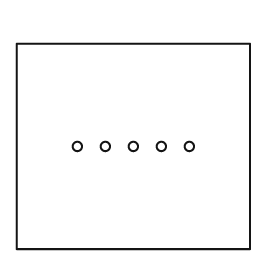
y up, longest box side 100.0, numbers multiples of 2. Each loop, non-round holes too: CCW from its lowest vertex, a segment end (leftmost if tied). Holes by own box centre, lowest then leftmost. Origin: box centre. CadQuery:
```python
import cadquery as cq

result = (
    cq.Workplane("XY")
    .moveTo(-50.0, -44.0)
    .lineTo(50.0, -44.0)
    .lineTo(50.0, 44.0)
    .lineTo(-50.0, 44.0)
    .close()
    .moveTo(-24.0, 0.0)
    .circle(2.0)
    .moveTo(-12.0, 0.0)
    .circle(2.0)
    .moveTo(0.0, 0.0)
    .circle(2.0)
    .moveTo(12.0, 0.0)
    .circle(2.0)
    .moveTo(24.0, 0.0)
    .circle(2.0)
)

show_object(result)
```